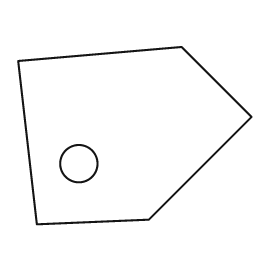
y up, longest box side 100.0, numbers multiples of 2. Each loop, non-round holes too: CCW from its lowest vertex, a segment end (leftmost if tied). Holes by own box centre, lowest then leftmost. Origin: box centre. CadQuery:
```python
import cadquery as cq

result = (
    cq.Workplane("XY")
    .moveTo(-42.0, -38.0)
    .lineTo(6.0, -36.0)
    .lineTo(50.0, 8.0)
    .lineTo(20.0, 38.0)
    .lineTo(-50.0, 32.0)
    .close()
    .moveTo(-24.0, -12.0)
    .circle(8.0)
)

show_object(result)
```